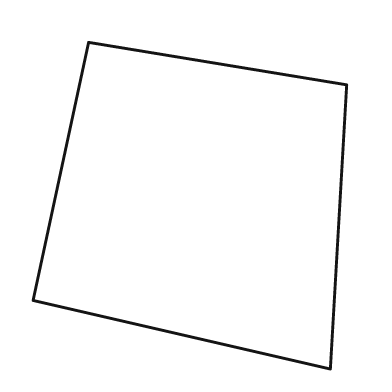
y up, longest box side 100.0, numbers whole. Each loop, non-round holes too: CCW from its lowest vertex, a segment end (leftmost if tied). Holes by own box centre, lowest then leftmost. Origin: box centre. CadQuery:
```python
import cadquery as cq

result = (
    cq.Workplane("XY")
    .moveTo(43.0, -50.0)
    .lineTo(48.0, 37.0)
    .lineTo(-31.0, 50.0)
    .lineTo(-48.0, -29.0)
    .close()
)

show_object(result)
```